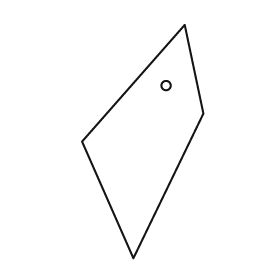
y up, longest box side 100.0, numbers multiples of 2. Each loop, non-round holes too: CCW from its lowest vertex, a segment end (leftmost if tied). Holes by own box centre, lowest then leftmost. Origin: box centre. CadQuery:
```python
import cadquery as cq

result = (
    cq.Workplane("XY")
    .moveTo(-4.0, -50.0)
    .lineTo(26.0, 12.0)
    .lineTo(18.0, 50.0)
    .lineTo(-26.0, 0.0)
    .close()
    .moveTo(10.0, 24.0)
    .circle(2.0)
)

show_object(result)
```